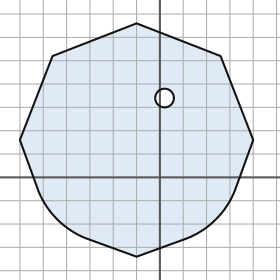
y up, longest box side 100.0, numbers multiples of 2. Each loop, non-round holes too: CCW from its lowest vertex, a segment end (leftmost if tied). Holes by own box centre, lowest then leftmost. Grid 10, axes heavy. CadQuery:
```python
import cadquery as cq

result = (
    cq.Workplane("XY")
    .moveTo(-10.0, -34.0)
    .lineTo(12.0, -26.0)
    .threePointArc((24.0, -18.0), (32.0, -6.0))
    .lineTo(40.0, 16.0)
    .lineTo(26.0, 52.0)
    .lineTo(-10.0, 66.0)
    .lineTo(-46.0, 52.0)
    .lineTo(-60.0, 16.0)
    .lineTo(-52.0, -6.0)
    .threePointArc((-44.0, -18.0), (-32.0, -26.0))
    .close()
    .moveTo(2.0, 34.0)
    .circle(4.0)
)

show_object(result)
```